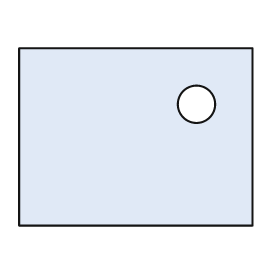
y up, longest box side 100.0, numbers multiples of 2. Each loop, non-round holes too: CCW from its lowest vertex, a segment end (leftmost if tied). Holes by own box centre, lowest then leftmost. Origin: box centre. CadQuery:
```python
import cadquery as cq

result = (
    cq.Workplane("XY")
    .moveTo(-50.0, -38.0)
    .lineTo(50.0, -38.0)
    .lineTo(50.0, 38.0)
    .lineTo(-50.0, 38.0)
    .close()
    .moveTo(26.0, 14.0)
    .circle(8.0)
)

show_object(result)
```